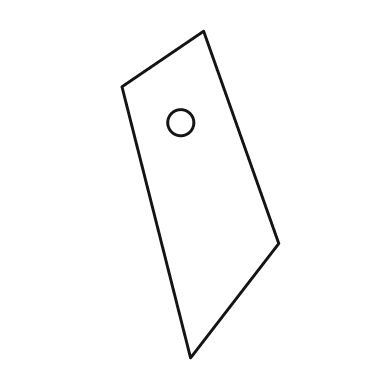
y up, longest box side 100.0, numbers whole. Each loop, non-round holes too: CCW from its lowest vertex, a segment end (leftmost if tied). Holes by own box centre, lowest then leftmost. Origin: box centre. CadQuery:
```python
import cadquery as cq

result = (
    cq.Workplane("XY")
    .moveTo(-3.0, -50.0)
    .lineTo(24.0, -15.0)
    .lineTo(1.0, 50.0)
    .lineTo(-24.0, 33.0)
    .close()
    .moveTo(-6.0, 22.0)
    .circle(4.0)
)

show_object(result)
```